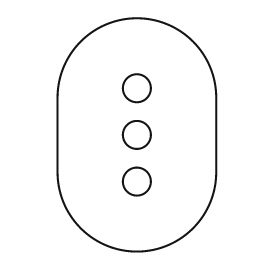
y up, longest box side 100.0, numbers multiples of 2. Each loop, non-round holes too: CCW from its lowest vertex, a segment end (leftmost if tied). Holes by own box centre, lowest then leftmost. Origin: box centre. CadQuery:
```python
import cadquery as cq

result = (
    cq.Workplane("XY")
    .moveTo(-34.0, -16.0)
    .threePointArc((0.0, -50.0), (34.0, -16.0))
    .lineTo(34.0, 16.0)
    .threePointArc((0.0, 50.0), (-34.0, 16.0))
    .close()
    .moveTo(0.0, -20.0)
    .circle(6.0)
    .moveTo(0.0, 0.0)
    .circle(6.0)
    .moveTo(0.0, 20.0)
    .circle(6.0)
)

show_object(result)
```